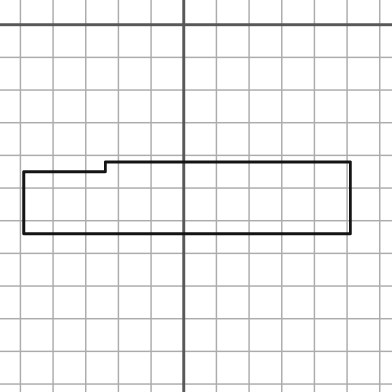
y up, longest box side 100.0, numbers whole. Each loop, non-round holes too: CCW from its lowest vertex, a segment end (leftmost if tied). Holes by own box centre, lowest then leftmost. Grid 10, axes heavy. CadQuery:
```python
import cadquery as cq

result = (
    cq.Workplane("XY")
    .moveTo(-49.0, -64.0)
    .lineTo(51.0, -64.0)
    .lineTo(51.0, -42.0)
    .lineTo(-24.0, -42.0)
    .lineTo(-24.0, -45.0)
    .lineTo(-49.0, -45.0)
    .close()
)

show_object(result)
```